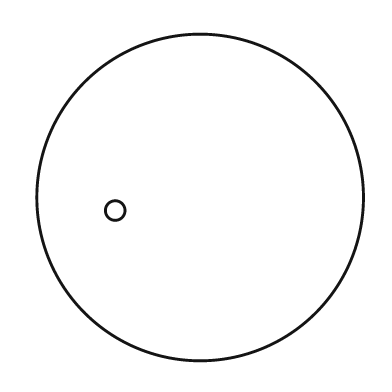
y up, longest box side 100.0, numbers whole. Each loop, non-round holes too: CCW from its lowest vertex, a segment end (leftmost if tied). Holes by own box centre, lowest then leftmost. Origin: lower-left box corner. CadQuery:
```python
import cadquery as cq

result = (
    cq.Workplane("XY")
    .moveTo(50.0, 50.0)
    .circle(50.0)
    .moveTo(24.0, 46.0)
    .circle(3.0)
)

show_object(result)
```